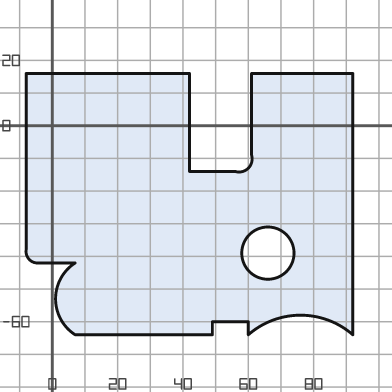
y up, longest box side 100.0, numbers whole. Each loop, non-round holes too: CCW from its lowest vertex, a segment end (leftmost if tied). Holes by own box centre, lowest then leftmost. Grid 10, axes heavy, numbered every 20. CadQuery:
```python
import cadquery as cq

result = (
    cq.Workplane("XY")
    .moveTo(7.0, -64.0)
    .lineTo(49.0, -64.0)
    .lineTo(49.0, -60.0)
    .lineTo(60.0, -60.0)
    .lineTo(60.0, -64.0)
    .threePointArc((76.0, -58.0), (92.0, -64.0))
    .lineTo(92.0, 16.0)
    .lineTo(61.0, 16.0)
    .lineTo(61.0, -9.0)
    .threePointArc((60.0, -13.0), (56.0, -14.0))
    .lineTo(42.0, -14.0)
    .lineTo(42.0, 16.0)
    .lineTo(-8.0, 16.0)
    .lineTo(-8.0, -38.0)
    .threePointArc((-7.0, -41.0), (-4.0, -42.0))
    .lineTo(7.0, -42.0)
    .threePointArc((1.0, -53.0), (7.0, -64.0))
    .close()
    .moveTo(66.0, -39.0)
    .circle(8.0)
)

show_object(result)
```